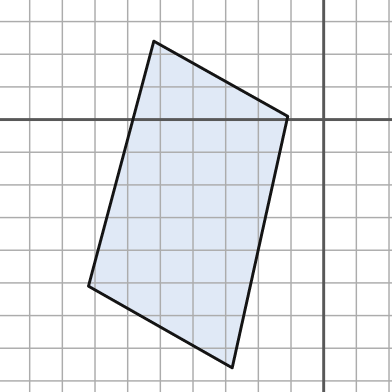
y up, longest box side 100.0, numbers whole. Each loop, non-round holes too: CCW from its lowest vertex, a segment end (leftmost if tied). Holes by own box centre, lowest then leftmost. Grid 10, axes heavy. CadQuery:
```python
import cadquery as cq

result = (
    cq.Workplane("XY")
    .moveTo(-28.0, -76.0)
    .lineTo(-11.0, 1.0)
    .lineTo(-52.0, 24.0)
    .lineTo(-72.0, -51.0)
    .close()
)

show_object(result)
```